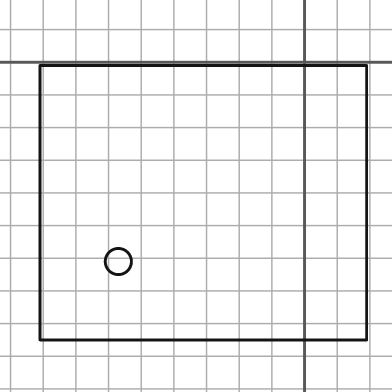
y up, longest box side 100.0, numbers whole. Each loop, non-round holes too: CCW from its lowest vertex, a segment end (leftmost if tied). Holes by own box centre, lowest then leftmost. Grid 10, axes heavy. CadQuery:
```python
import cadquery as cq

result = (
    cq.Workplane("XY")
    .moveTo(-81.0, -85.0)
    .lineTo(19.0, -85.0)
    .lineTo(19.0, -1.0)
    .lineTo(-81.0, -1.0)
    .close()
    .moveTo(-57.0, -61.0)
    .circle(4.0)
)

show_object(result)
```